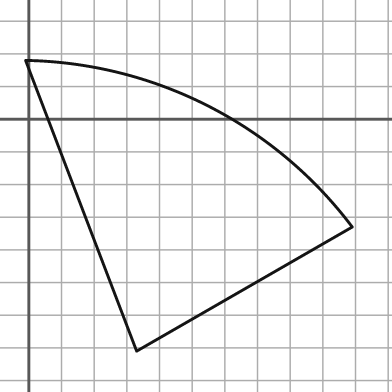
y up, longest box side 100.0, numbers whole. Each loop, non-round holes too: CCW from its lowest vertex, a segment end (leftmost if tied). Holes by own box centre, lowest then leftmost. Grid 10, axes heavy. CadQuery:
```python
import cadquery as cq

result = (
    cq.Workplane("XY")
    .moveTo(33.0, -71.0)
    .lineTo(99.0, -33.0)
    .threePointArc((55.0, 4.0), (-1.0, 18.0))
    .close()
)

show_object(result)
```